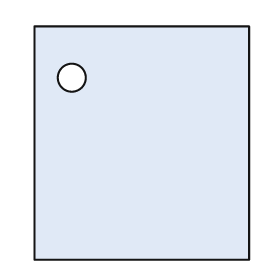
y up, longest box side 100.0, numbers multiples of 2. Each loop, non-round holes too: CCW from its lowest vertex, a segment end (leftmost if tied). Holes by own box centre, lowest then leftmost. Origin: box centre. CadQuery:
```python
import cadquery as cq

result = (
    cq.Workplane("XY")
    .moveTo(-46.0, -50.0)
    .lineTo(46.0, -50.0)
    .lineTo(46.0, 50.0)
    .lineTo(-46.0, 50.0)
    .close()
    .moveTo(-30.0, 28.0)
    .circle(6.0)
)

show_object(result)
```